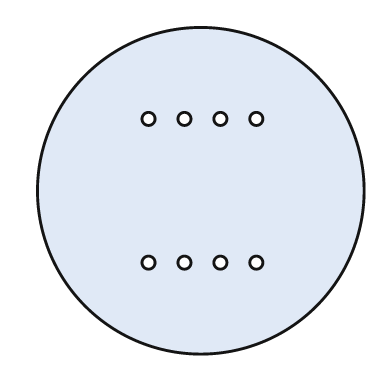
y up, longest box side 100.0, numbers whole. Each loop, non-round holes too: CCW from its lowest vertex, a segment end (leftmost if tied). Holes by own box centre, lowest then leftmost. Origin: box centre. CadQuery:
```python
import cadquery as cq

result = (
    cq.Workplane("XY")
    .moveTo(0.0, 0.0)
    .circle(50.0)
    .moveTo(-16.0, -22.0)
    .circle(2.0)
    .moveTo(-5.0, -22.0)
    .circle(2.0)
    .moveTo(6.0, -22.0)
    .circle(2.0)
    .moveTo(17.0, -22.0)
    .circle(2.0)
    .moveTo(-16.0, 22.0)
    .circle(2.0)
    .moveTo(-5.0, 22.0)
    .circle(2.0)
    .moveTo(6.0, 22.0)
    .circle(2.0)
    .moveTo(17.0, 22.0)
    .circle(2.0)
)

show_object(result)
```